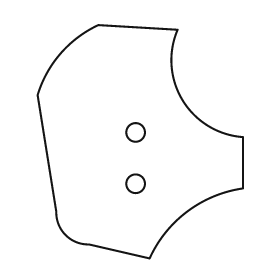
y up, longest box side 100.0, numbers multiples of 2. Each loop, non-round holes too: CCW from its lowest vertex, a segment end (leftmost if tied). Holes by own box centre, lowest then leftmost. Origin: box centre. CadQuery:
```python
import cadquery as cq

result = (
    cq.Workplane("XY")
    .moveTo(4.0, -50.0)
    .threePointArc((20.0, -30.0), (44.0, -20.0))
    .lineTo(44.0, 2.0)
    .threePointArc((18.0, 18.0), (16.0, 48.0))
    .lineTo(-18.0, 50.0)
    .threePointArc((-34.0, 38.0), (-44.0, 20.0))
    .lineTo(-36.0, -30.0)
    .threePointArc((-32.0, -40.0), (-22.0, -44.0))
    .close()
    .moveTo(-2.0, -18.0)
    .circle(4.0)
    .moveTo(-2.0, 4.0)
    .circle(4.0)
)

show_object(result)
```